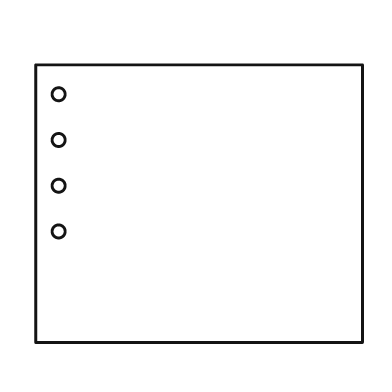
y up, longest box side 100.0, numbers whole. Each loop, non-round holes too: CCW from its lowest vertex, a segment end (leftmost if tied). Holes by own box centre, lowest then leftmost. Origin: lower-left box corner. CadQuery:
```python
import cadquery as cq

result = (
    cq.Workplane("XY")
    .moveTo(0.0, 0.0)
    .lineTo(100.0, 0.0)
    .lineTo(100.0, 85.0)
    .lineTo(0.0, 85.0)
    .close()
    .moveTo(7.0, 34.0)
    .circle(2.0)
    .moveTo(7.0, 48.0)
    .circle(2.0)
    .moveTo(7.0, 62.0)
    .circle(2.0)
    .moveTo(7.0, 76.0)
    .circle(2.0)
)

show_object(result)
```